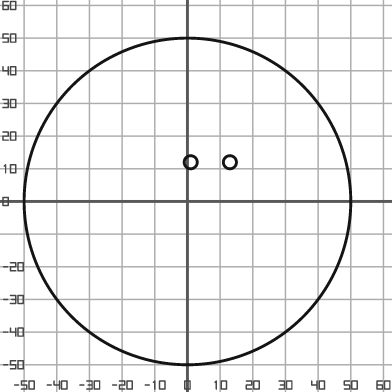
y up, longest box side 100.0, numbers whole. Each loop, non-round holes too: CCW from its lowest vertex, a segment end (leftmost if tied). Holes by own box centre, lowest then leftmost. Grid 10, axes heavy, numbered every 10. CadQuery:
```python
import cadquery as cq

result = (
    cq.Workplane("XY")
    .moveTo(0.0, 0.0)
    .circle(50.0)
    .moveTo(1.0, 12.0)
    .circle(2.0)
    .moveTo(13.0, 12.0)
    .circle(2.0)
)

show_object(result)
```